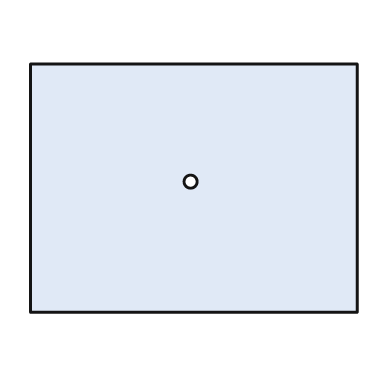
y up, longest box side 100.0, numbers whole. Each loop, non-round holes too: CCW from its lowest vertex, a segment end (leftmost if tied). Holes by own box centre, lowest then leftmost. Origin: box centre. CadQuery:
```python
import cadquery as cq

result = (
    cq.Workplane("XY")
    .moveTo(-50.0, -38.0)
    .lineTo(50.0, -38.0)
    .lineTo(50.0, 38.0)
    .lineTo(-50.0, 38.0)
    .close()
    .moveTo(-1.0, 2.0)
    .circle(2.0)
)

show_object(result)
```